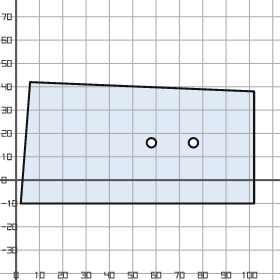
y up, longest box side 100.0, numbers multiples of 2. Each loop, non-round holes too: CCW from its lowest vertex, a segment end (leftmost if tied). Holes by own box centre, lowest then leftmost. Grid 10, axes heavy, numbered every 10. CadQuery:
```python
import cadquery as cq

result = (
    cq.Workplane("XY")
    .moveTo(2.0, -10.0)
    .lineTo(102.0, -10.0)
    .lineTo(102.0, 38.0)
    .lineTo(6.0, 42.0)
    .close()
    .moveTo(58.0, 16.0)
    .circle(2.0)
    .moveTo(76.0, 16.0)
    .circle(2.0)
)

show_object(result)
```